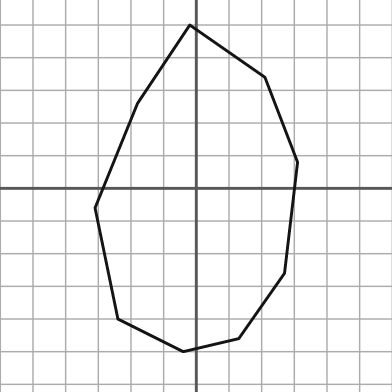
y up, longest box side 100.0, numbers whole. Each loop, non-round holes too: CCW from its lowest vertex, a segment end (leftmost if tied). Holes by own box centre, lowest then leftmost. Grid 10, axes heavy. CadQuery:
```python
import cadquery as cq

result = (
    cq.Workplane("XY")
    .moveTo(-4.0, -50.0)
    .lineTo(13.0, -46.0)
    .lineTo(27.0, -26.0)
    .lineTo(31.0, 8.0)
    .lineTo(21.0, 34.0)
    .lineTo(-2.0, 50.0)
    .lineTo(-18.0, 26.0)
    .lineTo(-31.0, -6.0)
    .lineTo(-24.0, -40.0)
    .close()
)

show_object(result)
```